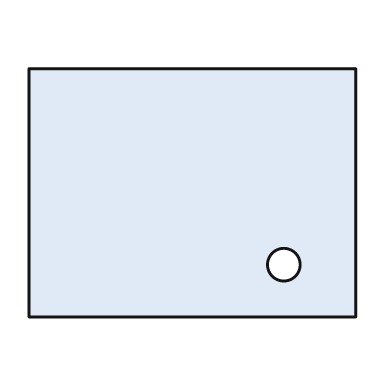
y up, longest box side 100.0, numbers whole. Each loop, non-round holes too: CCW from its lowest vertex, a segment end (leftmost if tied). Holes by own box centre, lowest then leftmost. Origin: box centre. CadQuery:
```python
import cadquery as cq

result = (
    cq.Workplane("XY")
    .moveTo(-50.0, -38.0)
    .lineTo(50.0, -38.0)
    .lineTo(50.0, 38.0)
    .lineTo(-50.0, 38.0)
    .close()
    .moveTo(28.0, -22.0)
    .circle(5.0)
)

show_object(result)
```